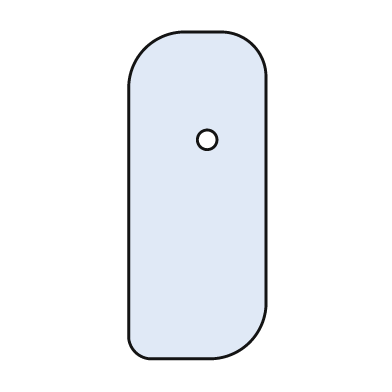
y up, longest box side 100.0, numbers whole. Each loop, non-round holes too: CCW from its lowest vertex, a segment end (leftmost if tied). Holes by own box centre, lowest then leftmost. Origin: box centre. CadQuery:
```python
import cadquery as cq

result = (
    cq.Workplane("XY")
    .moveTo(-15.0, -50.0)
    .lineTo(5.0, -50.0)
    .threePointArc((16.0, -45.0), (21.0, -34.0))
    .lineTo(21.0, 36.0)
    .threePointArc((17.0, 46.0), (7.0, 50.0))
    .lineTo(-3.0, 50.0)
    .threePointArc((-16.0, 45.0), (-21.0, 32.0))
    .lineTo(-21.0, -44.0)
    .threePointArc((-19.0, -48.0), (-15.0, -50.0))
    .close()
    .moveTo(3.0, 17.0)
    .circle(3.0)
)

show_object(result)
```